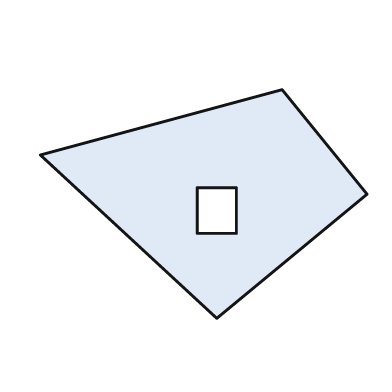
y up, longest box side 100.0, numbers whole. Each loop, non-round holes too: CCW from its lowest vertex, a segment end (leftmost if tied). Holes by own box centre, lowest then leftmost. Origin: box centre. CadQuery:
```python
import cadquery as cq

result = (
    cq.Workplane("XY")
    .moveTo(4.0, -35.0)
    .lineTo(50.0, 3.0)
    .lineTo(24.0, 35.0)
    .lineTo(-50.0, 15.0)
    .close()
    .moveTo(-2.0, -9.0)
    .lineTo(10.0, -9.0)
    .lineTo(10.0, 5.0)
    .lineTo(-2.0, 5.0)
    .close()
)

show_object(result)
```